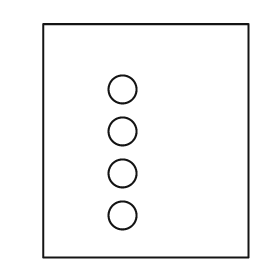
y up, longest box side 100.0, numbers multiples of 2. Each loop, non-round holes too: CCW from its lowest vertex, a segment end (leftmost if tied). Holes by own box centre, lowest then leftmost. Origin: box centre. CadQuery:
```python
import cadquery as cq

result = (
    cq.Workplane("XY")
    .moveTo(-44.0, -50.0)
    .lineTo(44.0, -50.0)
    .lineTo(44.0, 50.0)
    .lineTo(-44.0, 50.0)
    .close()
    .moveTo(-10.0, -32.0)
    .circle(6.0)
    .moveTo(-10.0, -14.0)
    .circle(6.0)
    .moveTo(-10.0, 4.0)
    .circle(6.0)
    .moveTo(-10.0, 22.0)
    .circle(6.0)
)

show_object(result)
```